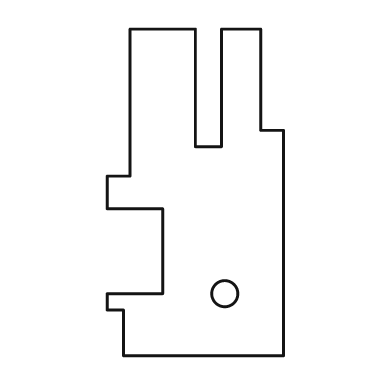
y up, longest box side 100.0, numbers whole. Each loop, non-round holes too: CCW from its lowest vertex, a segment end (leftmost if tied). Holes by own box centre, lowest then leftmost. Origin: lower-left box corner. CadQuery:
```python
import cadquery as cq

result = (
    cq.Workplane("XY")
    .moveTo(5.0, 0.0)
    .lineTo(54.0, 0.0)
    .lineTo(54.0, 69.0)
    .lineTo(47.0, 69.0)
    .lineTo(47.0, 100.0)
    .lineTo(35.0, 100.0)
    .lineTo(35.0, 64.0)
    .lineTo(27.0, 64.0)
    .lineTo(27.0, 100.0)
    .lineTo(7.0, 100.0)
    .lineTo(7.0, 55.0)
    .lineTo(0.0, 55.0)
    .lineTo(0.0, 45.0)
    .lineTo(17.0, 45.0)
    .lineTo(17.0, 19.0)
    .lineTo(0.0, 19.0)
    .lineTo(0.0, 14.0)
    .lineTo(5.0, 14.0)
    .close()
    .moveTo(36.0, 19.0)
    .circle(4.0)
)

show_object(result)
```